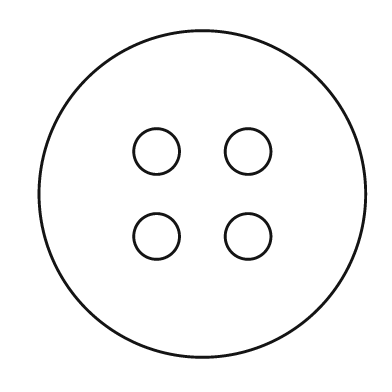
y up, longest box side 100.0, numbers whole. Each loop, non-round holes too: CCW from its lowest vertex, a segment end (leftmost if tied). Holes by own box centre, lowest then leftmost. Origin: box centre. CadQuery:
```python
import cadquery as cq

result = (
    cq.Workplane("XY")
    .moveTo(0.0, 0.0)
    .circle(50.0)
    .moveTo(-14.0, -13.0)
    .circle(7.0)
    .moveTo(14.0, -13.0)
    .circle(7.0)
    .moveTo(-14.0, 13.0)
    .circle(7.0)
    .moveTo(14.0, 13.0)
    .circle(7.0)
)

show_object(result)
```